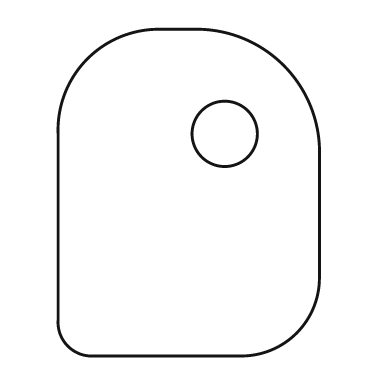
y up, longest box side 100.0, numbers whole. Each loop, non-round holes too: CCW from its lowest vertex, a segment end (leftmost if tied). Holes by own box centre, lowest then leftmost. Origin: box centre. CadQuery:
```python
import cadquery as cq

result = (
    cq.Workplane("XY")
    .moveTo(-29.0, -50.0)
    .lineTo(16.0, -50.0)
    .threePointArc((33.0, -43.0), (40.0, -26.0))
    .lineTo(40.0, 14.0)
    .threePointArc((29.0, 39.0), (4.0, 50.0))
    .lineTo(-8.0, 50.0)
    .threePointArc((-31.0, 41.0), (-40.0, 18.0))
    .lineTo(-40.0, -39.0)
    .threePointArc((-37.0, -47.0), (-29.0, -50.0))
    .close()
    .moveTo(11.0, 18.0)
    .circle(10.0)
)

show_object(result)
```